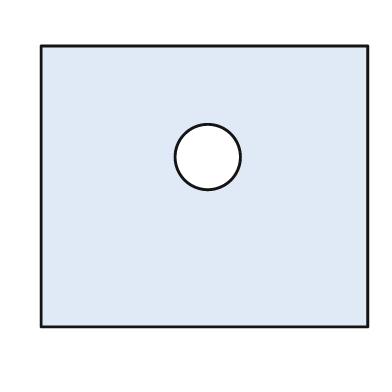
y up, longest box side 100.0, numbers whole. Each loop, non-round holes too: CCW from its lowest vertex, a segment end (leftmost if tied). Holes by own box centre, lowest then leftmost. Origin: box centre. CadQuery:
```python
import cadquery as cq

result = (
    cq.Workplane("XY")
    .moveTo(-50.0, -43.0)
    .lineTo(50.0, -43.0)
    .lineTo(50.0, 43.0)
    .lineTo(-50.0, 43.0)
    .close()
    .moveTo(1.0, 9.0)
    .circle(10.0)
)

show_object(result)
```